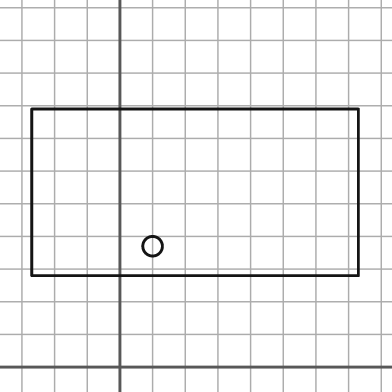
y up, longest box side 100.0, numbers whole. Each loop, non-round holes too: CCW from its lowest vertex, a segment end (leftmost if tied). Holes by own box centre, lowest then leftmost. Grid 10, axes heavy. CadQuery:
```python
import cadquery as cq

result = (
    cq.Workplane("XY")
    .moveTo(-27.0, 28.0)
    .lineTo(73.0, 28.0)
    .lineTo(73.0, 79.0)
    .lineTo(-27.0, 79.0)
    .close()
    .moveTo(10.0, 37.0)
    .circle(3.0)
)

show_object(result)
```